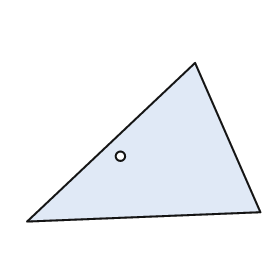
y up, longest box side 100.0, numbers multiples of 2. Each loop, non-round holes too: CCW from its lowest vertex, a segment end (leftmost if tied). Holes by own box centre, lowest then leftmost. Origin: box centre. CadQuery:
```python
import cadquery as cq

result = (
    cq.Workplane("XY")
    .moveTo(-50.0, -34.0)
    .lineTo(50.0, -30.0)
    .lineTo(22.0, 34.0)
    .close()
    .moveTo(-10.0, -6.0)
    .circle(2.0)
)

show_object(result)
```